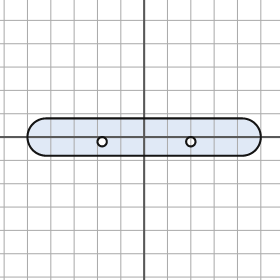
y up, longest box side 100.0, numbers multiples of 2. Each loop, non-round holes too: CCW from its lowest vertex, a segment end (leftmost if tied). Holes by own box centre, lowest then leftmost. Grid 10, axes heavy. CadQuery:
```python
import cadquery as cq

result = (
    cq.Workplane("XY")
    .moveTo(-42.0, -8.0)
    .lineTo(42.0, -8.0)
    .threePointArc((50.0, 0.0), (42.0, 8.0))
    .lineTo(-42.0, 8.0)
    .threePointArc((-50.0, 0.0), (-42.0, -8.0))
    .close()
    .moveTo(-18.0, -2.0)
    .circle(2.0)
    .moveTo(20.0, -2.0)
    .circle(2.0)
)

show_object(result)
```